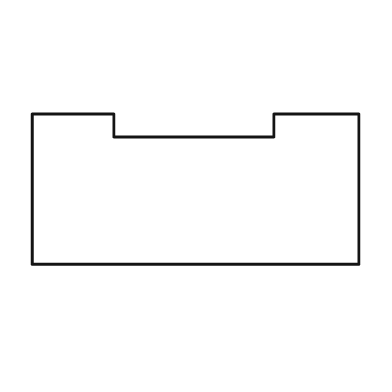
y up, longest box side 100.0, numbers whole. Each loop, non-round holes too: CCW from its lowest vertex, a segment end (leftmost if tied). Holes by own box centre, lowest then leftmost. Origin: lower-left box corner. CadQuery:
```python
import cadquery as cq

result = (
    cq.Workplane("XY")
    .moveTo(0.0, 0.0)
    .lineTo(100.0, 0.0)
    .lineTo(100.0, 46.0)
    .lineTo(74.0, 46.0)
    .lineTo(74.0, 39.0)
    .lineTo(25.0, 39.0)
    .lineTo(25.0, 46.0)
    .lineTo(0.0, 46.0)
    .close()
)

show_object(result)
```